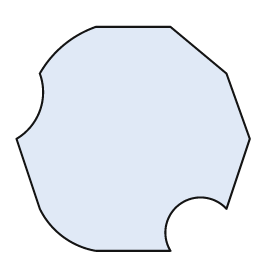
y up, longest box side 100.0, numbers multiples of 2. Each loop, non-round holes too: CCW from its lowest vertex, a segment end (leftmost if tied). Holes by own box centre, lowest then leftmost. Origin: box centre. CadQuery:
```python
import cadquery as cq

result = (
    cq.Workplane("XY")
    .moveTo(-16.0, -48.0)
    .lineTo(16.0, -48.0)
    .threePointArc((20.0, -28.0), (40.0, -30.0))
    .lineTo(50.0, 0.0)
    .lineTo(40.0, 28.0)
    .lineTo(16.0, 48.0)
    .lineTo(-16.0, 48.0)
    .threePointArc((-30.0, 40.0), (-40.0, 28.0))
    .threePointArc((-40.0, 12.0), (-50.0, 0.0))
    .lineTo(-40.0, -30.0)
    .threePointArc((-30.0, -42.0), (-16.0, -48.0))
    .close()
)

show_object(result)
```